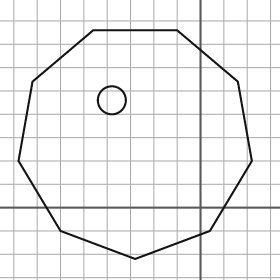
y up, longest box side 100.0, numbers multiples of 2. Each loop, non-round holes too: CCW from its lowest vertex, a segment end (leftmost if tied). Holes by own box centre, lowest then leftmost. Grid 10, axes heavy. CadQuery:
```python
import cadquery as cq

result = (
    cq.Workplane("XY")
    .moveTo(-28.0, -22.0)
    .lineTo(4.0, -10.0)
    .lineTo(22.0, 20.0)
    .lineTo(16.0, 54.0)
    .lineTo(-10.0, 76.0)
    .lineTo(-46.0, 76.0)
    .lineTo(-72.0, 54.0)
    .lineTo(-78.0, 20.0)
    .lineTo(-60.0, -10.0)
    .close()
    .moveTo(-38.0, 46.0)
    .circle(6.0)
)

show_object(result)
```